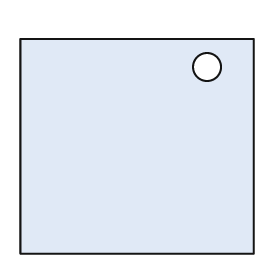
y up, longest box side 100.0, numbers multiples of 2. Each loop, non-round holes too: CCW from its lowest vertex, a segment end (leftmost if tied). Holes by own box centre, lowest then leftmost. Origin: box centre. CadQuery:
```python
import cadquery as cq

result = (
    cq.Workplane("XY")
    .moveTo(-50.0, -46.0)
    .lineTo(50.0, -46.0)
    .lineTo(50.0, 46.0)
    .lineTo(-50.0, 46.0)
    .close()
    .moveTo(30.0, 34.0)
    .circle(6.0)
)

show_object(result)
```